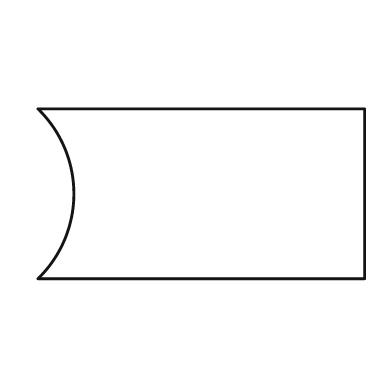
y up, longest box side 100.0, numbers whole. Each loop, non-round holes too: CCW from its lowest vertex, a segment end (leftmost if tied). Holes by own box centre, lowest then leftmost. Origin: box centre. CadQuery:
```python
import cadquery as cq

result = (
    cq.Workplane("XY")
    .moveTo(-50.0, -26.0)
    .lineTo(50.0, -26.0)
    .lineTo(50.0, 26.0)
    .lineTo(-50.0, 26.0)
    .threePointArc((-39.0, 0.0), (-50.0, -26.0))
    .close()
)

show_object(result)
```